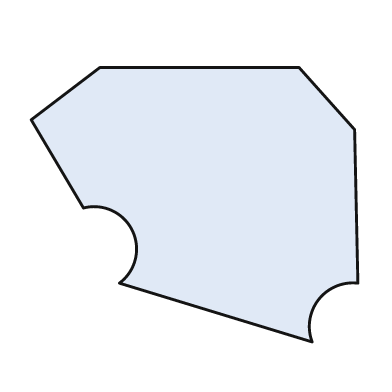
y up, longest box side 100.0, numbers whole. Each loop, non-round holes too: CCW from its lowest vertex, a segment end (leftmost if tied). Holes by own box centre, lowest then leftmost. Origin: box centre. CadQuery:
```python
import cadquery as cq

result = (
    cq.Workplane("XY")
    .moveTo(36.0, -42.0)
    .threePointArc((38.0, -29.0), (50.0, -24.0))
    .lineTo(49.0, 23.0)
    .lineTo(32.0, 42.0)
    .lineTo(-29.0, 42.0)
    .lineTo(-50.0, 26.0)
    .lineTo(-34.0, -1.0)
    .threePointArc((-19.0, -8.0), (-23.0, -24.0))
    .close()
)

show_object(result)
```